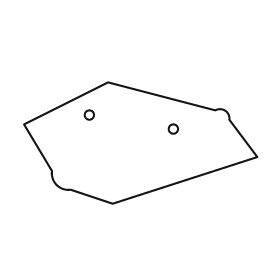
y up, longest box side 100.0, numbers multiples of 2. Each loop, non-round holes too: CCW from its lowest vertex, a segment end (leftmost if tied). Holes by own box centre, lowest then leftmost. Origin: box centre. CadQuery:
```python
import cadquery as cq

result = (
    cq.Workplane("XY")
    .moveTo(-12.0, -26.0)
    .lineTo(50.0, -6.0)
    .lineTo(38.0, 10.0)
    .threePointArc((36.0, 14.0), (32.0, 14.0))
    .lineTo(-14.0, 26.0)
    .lineTo(-50.0, 8.0)
    .lineTo(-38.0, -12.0)
    .threePointArc((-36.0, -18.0), (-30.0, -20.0))
    .close()
    .moveTo(14.0, 6.0)
    .circle(2.0)
    .moveTo(-22.0, 12.0)
    .circle(2.0)
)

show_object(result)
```